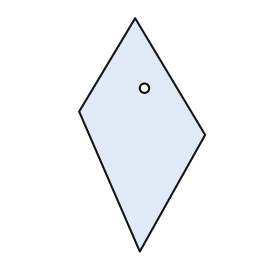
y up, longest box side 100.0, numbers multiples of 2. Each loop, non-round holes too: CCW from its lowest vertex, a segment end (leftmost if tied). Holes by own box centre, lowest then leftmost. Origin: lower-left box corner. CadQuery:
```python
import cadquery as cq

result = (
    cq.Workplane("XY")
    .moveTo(26.0, 0.0)
    .lineTo(54.0, 50.0)
    .lineTo(24.0, 100.0)
    .lineTo(0.0, 60.0)
    .close()
    .moveTo(28.0, 70.0)
    .circle(2.0)
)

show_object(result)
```